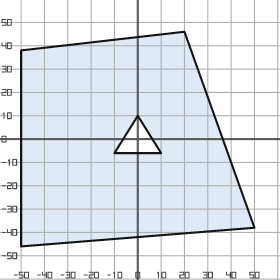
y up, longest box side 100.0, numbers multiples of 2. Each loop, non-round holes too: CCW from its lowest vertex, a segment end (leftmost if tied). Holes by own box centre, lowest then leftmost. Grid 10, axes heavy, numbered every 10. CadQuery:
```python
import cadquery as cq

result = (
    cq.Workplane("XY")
    .moveTo(-50.0, -46.0)
    .lineTo(50.0, -38.0)
    .lineTo(20.0, 46.0)
    .lineTo(-50.0, 38.0)
    .close()
    .moveTo(-10.0, -6.0)
    .lineTo(10.0, -6.0)
    .lineTo(0.0, 10.0)
    .close()
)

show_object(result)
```